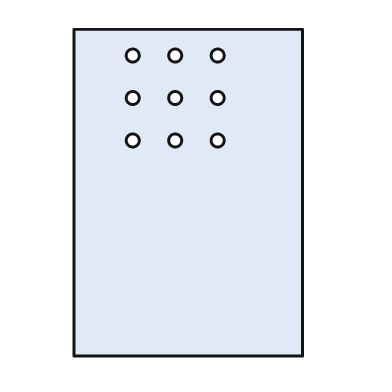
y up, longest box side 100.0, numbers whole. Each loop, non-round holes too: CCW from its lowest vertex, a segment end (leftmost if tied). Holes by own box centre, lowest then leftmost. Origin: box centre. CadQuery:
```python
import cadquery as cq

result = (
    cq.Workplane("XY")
    .moveTo(-35.0, -50.0)
    .lineTo(35.0, -50.0)
    .lineTo(35.0, 50.0)
    .lineTo(-35.0, 50.0)
    .close()
    .moveTo(-17.0, 16.0)
    .circle(2.0)
    .moveTo(-4.0, 16.0)
    .circle(2.0)
    .moveTo(9.0, 16.0)
    .circle(2.0)
    .moveTo(-17.0, 29.0)
    .circle(2.0)
    .moveTo(-4.0, 29.0)
    .circle(2.0)
    .moveTo(9.0, 29.0)
    .circle(2.0)
    .moveTo(-17.0, 42.0)
    .circle(2.0)
    .moveTo(-4.0, 42.0)
    .circle(2.0)
    .moveTo(9.0, 42.0)
    .circle(2.0)
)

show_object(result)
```